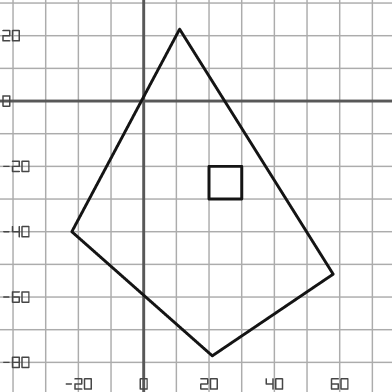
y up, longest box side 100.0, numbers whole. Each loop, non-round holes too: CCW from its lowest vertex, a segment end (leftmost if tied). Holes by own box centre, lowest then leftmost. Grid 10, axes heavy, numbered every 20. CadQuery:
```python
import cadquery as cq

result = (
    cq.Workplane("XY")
    .moveTo(21.0, -78.0)
    .lineTo(58.0, -53.0)
    .lineTo(11.0, 22.0)
    .lineTo(-22.0, -40.0)
    .close()
    .moveTo(20.0, -30.0)
    .lineTo(30.0, -30.0)
    .lineTo(30.0, -20.0)
    .lineTo(20.0, -20.0)
    .close()
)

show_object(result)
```